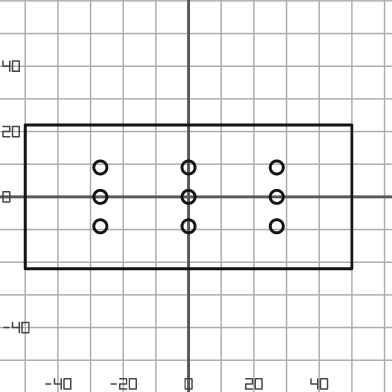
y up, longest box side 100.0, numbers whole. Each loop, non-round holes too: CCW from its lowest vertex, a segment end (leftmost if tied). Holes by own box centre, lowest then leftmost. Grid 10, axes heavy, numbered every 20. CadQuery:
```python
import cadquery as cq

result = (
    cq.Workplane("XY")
    .moveTo(-50.0, -22.0)
    .lineTo(50.0, -22.0)
    .lineTo(50.0, 22.0)
    .lineTo(-50.0, 22.0)
    .close()
    .moveTo(-27.0, -9.0)
    .circle(2.0)
    .moveTo(0.0, -9.0)
    .circle(2.0)
    .moveTo(27.0, -9.0)
    .circle(2.0)
    .moveTo(-27.0, 0.0)
    .circle(2.0)
    .moveTo(0.0, 0.0)
    .circle(2.0)
    .moveTo(27.0, 0.0)
    .circle(2.0)
    .moveTo(-27.0, 9.0)
    .circle(2.0)
    .moveTo(0.0, 9.0)
    .circle(2.0)
    .moveTo(27.0, 9.0)
    .circle(2.0)
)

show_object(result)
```